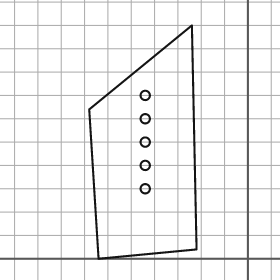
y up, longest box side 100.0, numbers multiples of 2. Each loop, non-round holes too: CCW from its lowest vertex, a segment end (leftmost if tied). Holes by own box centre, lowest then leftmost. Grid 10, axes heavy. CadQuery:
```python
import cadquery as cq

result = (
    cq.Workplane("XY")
    .moveTo(-64.0, 0.0)
    .lineTo(-22.0, 4.0)
    .lineTo(-24.0, 100.0)
    .lineTo(-68.0, 64.0)
    .close()
    .moveTo(-44.0, 30.0)
    .circle(2.0)
    .moveTo(-44.0, 40.0)
    .circle(2.0)
    .moveTo(-44.0, 50.0)
    .circle(2.0)
    .moveTo(-44.0, 60.0)
    .circle(2.0)
    .moveTo(-44.0, 70.0)
    .circle(2.0)
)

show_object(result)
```